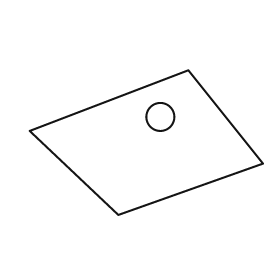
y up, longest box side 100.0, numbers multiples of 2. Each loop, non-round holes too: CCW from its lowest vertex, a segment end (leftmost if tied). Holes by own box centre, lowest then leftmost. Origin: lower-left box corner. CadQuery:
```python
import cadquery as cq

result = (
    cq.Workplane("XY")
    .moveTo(38.0, 0.0)
    .lineTo(100.0, 22.0)
    .lineTo(68.0, 62.0)
    .lineTo(0.0, 36.0)
    .close()
    .moveTo(56.0, 42.0)
    .circle(6.0)
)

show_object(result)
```